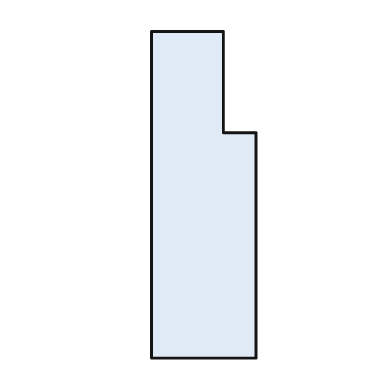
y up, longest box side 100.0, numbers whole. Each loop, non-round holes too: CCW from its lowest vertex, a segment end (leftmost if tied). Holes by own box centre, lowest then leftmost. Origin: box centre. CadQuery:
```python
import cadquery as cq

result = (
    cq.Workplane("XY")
    .moveTo(-16.0, -50.0)
    .lineTo(16.0, -50.0)
    .lineTo(16.0, 19.0)
    .lineTo(6.0, 19.0)
    .lineTo(6.0, 50.0)
    .lineTo(-16.0, 50.0)
    .close()
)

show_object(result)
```